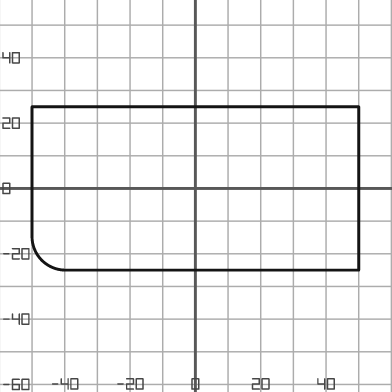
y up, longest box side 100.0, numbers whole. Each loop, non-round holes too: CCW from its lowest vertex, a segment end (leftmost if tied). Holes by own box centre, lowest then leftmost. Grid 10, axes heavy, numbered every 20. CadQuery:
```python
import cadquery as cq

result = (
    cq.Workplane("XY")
    .moveTo(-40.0, -25.0)
    .lineTo(50.0, -25.0)
    .lineTo(50.0, 25.0)
    .lineTo(-50.0, 25.0)
    .lineTo(-50.0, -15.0)
    .threePointArc((-47.0, -22.0), (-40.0, -25.0))
    .close()
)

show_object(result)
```